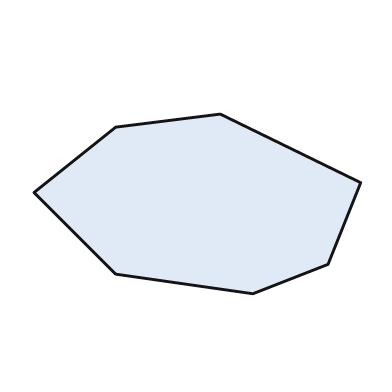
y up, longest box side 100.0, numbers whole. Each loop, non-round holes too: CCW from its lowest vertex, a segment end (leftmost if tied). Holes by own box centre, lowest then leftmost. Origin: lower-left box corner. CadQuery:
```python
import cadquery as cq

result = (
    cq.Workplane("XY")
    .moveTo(67.0, 0.0)
    .lineTo(90.0, 9.0)
    .lineTo(100.0, 34.0)
    .lineTo(57.0, 55.0)
    .lineTo(25.0, 51.0)
    .lineTo(0.0, 31.0)
    .lineTo(25.0, 6.0)
    .close()
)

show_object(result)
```